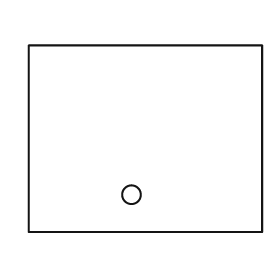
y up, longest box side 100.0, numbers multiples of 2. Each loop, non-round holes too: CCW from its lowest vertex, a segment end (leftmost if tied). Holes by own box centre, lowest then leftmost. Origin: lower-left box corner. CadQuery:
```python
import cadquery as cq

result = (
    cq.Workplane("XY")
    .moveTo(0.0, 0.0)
    .lineTo(100.0, 0.0)
    .lineTo(100.0, 80.0)
    .lineTo(0.0, 80.0)
    .close()
    .moveTo(44.0, 16.0)
    .circle(4.0)
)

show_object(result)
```